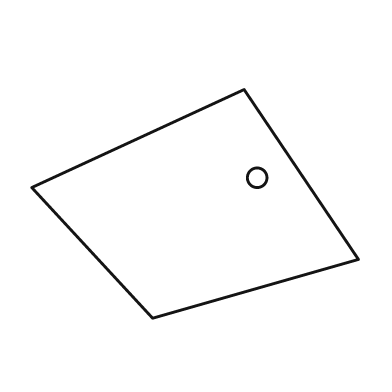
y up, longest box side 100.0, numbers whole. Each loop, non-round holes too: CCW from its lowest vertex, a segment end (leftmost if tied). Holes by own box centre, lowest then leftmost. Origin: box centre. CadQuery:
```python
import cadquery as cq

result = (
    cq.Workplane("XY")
    .moveTo(-13.0, -35.0)
    .lineTo(50.0, -17.0)
    .lineTo(15.0, 35.0)
    .lineTo(-50.0, 5.0)
    .close()
    .moveTo(19.0, 8.0)
    .circle(3.0)
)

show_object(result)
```